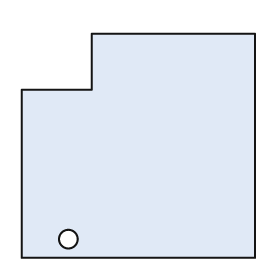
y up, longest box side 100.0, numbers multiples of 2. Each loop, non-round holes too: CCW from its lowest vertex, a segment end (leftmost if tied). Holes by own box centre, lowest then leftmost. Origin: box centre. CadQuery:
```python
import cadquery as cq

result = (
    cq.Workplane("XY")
    .moveTo(-50.0, -48.0)
    .lineTo(50.0, -48.0)
    .lineTo(50.0, 48.0)
    .lineTo(-20.0, 48.0)
    .lineTo(-20.0, 24.0)
    .lineTo(-50.0, 24.0)
    .close()
    .moveTo(-30.0, -40.0)
    .circle(4.0)
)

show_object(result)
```